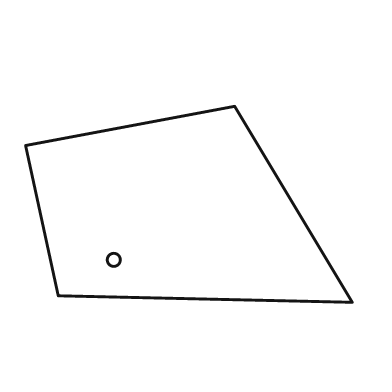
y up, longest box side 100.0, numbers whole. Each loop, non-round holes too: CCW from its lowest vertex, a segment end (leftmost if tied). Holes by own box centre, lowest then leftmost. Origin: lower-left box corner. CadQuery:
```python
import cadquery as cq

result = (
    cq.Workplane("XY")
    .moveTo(100.0, 0.0)
    .lineTo(64.0, 60.0)
    .lineTo(0.0, 48.0)
    .lineTo(10.0, 2.0)
    .close()
    .moveTo(27.0, 13.0)
    .circle(2.0)
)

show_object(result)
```